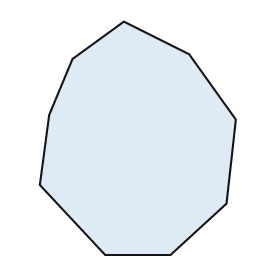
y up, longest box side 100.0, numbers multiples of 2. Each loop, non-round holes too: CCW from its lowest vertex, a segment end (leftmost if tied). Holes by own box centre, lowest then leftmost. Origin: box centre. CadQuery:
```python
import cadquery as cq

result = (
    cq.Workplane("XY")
    .moveTo(-14.0, -50.0)
    .lineTo(14.0, -50.0)
    .lineTo(38.0, -28.0)
    .lineTo(42.0, 8.0)
    .lineTo(22.0, 36.0)
    .lineTo(-6.0, 50.0)
    .lineTo(-28.0, 34.0)
    .lineTo(-38.0, 10.0)
    .lineTo(-42.0, -20.0)
    .close()
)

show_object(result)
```